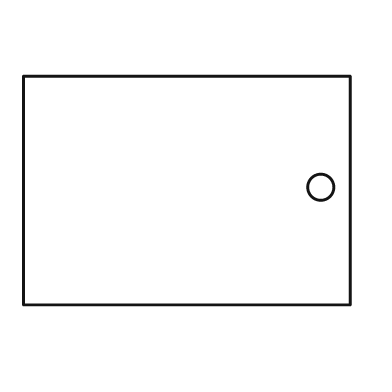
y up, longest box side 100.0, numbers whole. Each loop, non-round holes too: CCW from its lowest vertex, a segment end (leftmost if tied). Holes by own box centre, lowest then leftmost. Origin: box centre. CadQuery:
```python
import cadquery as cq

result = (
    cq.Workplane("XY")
    .moveTo(-50.0, -35.0)
    .lineTo(50.0, -35.0)
    .lineTo(50.0, 35.0)
    .lineTo(-50.0, 35.0)
    .close()
    .moveTo(41.0, 1.0)
    .circle(4.0)
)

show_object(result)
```